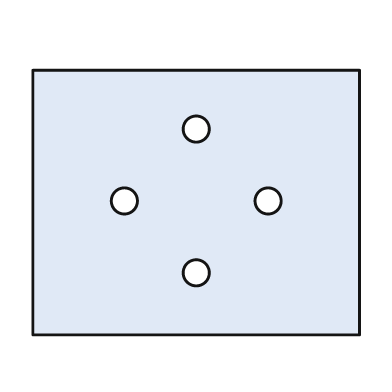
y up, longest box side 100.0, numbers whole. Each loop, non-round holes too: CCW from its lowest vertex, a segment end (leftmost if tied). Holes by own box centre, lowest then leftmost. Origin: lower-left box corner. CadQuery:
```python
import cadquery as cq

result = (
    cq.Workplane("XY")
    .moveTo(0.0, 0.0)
    .lineTo(100.0, 0.0)
    .lineTo(100.0, 81.0)
    .lineTo(0.0, 81.0)
    .close()
    .moveTo(50.0, 19.0)
    .circle(4.0)
    .moveTo(28.0, 41.0)
    .circle(4.0)
    .moveTo(72.0, 41.0)
    .circle(4.0)
    .moveTo(50.0, 63.0)
    .circle(4.0)
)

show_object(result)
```